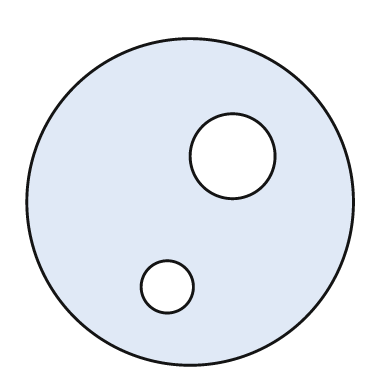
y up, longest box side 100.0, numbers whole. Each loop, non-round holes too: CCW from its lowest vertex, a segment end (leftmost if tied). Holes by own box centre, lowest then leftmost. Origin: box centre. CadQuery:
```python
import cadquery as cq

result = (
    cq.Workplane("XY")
    .moveTo(0.0, 0.0)
    .circle(50.0)
    .moveTo(-7.0, -26.0)
    .circle(8.0)
    .moveTo(13.0, 14.0)
    .circle(13.0)
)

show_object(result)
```